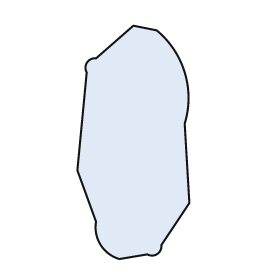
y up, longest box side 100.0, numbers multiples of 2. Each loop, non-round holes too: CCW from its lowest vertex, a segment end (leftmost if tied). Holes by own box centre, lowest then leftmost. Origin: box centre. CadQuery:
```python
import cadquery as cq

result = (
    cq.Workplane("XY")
    .moveTo(-6.0, -50.0)
    .lineTo(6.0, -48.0)
    .threePointArc((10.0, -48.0), (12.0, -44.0))
    .lineTo(24.0, -26.0)
    .lineTo(22.0, 8.0)
    .threePointArc((22.0, 30.0), (10.0, 48.0))
    .lineTo(0.0, 50.0)
    .lineTo(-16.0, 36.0)
    .threePointArc((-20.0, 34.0), (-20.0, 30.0))
    .lineTo(-24.0, -12.0)
    .lineTo(-16.0, -34.0)
    .threePointArc((-14.0, -44.0), (-6.0, -50.0))
    .close()
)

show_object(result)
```